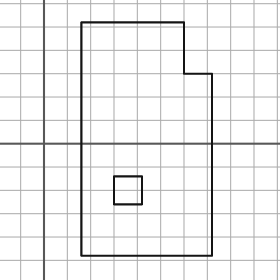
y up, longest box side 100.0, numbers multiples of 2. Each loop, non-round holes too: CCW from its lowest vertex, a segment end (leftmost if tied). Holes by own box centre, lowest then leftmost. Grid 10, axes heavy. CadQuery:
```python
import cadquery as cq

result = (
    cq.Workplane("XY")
    .moveTo(16.0, -48.0)
    .lineTo(72.0, -48.0)
    .lineTo(72.0, 30.0)
    .lineTo(60.0, 30.0)
    .lineTo(60.0, 52.0)
    .lineTo(16.0, 52.0)
    .close()
    .moveTo(30.0, -26.0)
    .lineTo(42.0, -26.0)
    .lineTo(42.0, -14.0)
    .lineTo(30.0, -14.0)
    .close()
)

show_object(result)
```